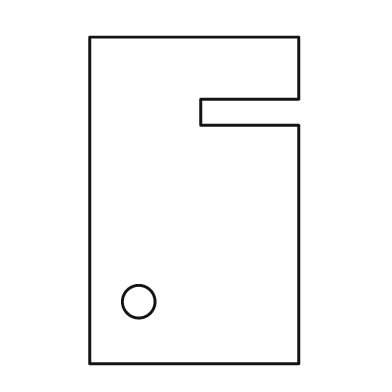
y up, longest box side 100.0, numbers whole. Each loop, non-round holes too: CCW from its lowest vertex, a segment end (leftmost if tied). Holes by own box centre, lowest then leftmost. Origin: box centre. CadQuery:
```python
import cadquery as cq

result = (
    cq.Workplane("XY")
    .moveTo(-32.0, -50.0)
    .lineTo(32.0, -50.0)
    .lineTo(32.0, 23.0)
    .lineTo(2.0, 23.0)
    .lineTo(2.0, 31.0)
    .lineTo(32.0, 31.0)
    .lineTo(32.0, 50.0)
    .lineTo(-32.0, 50.0)
    .close()
    .moveTo(-17.0, -31.0)
    .circle(5.0)
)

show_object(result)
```